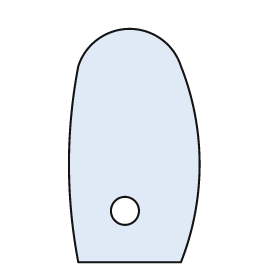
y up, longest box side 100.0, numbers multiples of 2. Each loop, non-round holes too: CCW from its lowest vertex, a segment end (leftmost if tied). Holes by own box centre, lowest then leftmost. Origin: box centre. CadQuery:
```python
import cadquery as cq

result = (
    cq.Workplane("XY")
    .moveTo(-24.0, -50.0)
    .lineTo(20.0, -50.0)
    .threePointArc((28.0, -8.0), (20.0, 34.0))
    .threePointArc((-2.0, 50.0), (-24.0, 34.0))
    .threePointArc((-28.0, -8.0), (-24.0, -50.0))
    .close()
    .moveTo(-4.0, -28.0)
    .circle(6.0)
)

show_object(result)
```